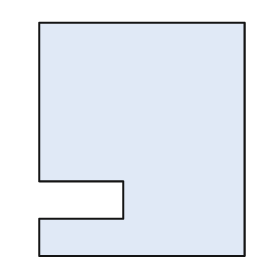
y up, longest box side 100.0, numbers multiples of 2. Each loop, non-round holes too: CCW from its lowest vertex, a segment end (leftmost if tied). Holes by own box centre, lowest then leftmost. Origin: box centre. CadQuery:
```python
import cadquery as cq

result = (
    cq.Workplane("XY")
    .moveTo(-44.0, -50.0)
    .lineTo(44.0, -50.0)
    .lineTo(44.0, 50.0)
    .lineTo(-44.0, 50.0)
    .lineTo(-44.0, -18.0)
    .lineTo(-8.0, -18.0)
    .lineTo(-8.0, -34.0)
    .lineTo(-44.0, -34.0)
    .close()
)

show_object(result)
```